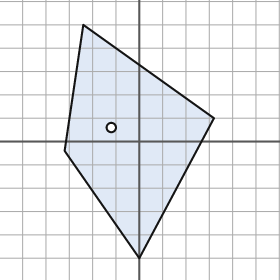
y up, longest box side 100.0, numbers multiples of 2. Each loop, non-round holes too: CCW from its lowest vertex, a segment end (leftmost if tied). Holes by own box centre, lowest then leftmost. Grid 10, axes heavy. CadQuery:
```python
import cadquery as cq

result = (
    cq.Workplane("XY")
    .moveTo(0.0, -50.0)
    .lineTo(32.0, 10.0)
    .lineTo(-24.0, 50.0)
    .lineTo(-32.0, -4.0)
    .close()
    .moveTo(-12.0, 6.0)
    .circle(2.0)
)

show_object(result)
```